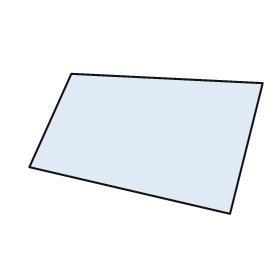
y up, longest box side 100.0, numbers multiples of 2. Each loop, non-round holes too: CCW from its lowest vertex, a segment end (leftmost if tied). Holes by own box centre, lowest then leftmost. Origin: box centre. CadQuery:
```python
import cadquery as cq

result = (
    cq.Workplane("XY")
    .moveTo(36.0, -30.0)
    .lineTo(50.0, 26.0)
    .lineTo(-32.0, 30.0)
    .lineTo(-50.0, -10.0)
    .close()
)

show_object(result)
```